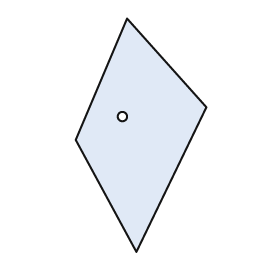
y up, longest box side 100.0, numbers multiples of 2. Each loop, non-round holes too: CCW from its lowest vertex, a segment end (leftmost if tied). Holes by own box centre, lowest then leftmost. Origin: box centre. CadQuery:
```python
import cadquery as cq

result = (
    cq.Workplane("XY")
    .moveTo(-2.0, -50.0)
    .lineTo(28.0, 12.0)
    .lineTo(-6.0, 50.0)
    .lineTo(-28.0, -2.0)
    .close()
    .moveTo(-8.0, 8.0)
    .circle(2.0)
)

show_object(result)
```